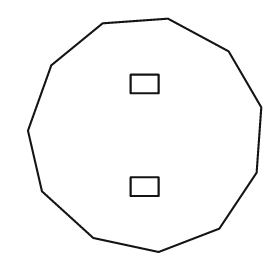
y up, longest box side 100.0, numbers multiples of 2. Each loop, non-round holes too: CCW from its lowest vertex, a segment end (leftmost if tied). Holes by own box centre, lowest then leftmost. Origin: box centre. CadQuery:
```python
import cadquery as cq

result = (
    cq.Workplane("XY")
    .moveTo(6.0, -50.0)
    .lineTo(32.0, -40.0)
    .lineTo(48.0, -16.0)
    .lineTo(50.0, 12.0)
    .lineTo(36.0, 36.0)
    .lineTo(10.0, 50.0)
    .lineTo(-18.0, 48.0)
    .lineTo(-40.0, 30.0)
    .lineTo(-50.0, 2.0)
    .lineTo(-44.0, -24.0)
    .lineTo(-22.0, -44.0)
    .close()
    .moveTo(-6.0, -26.0)
    .lineTo(6.0, -26.0)
    .lineTo(6.0, -18.0)
    .lineTo(-6.0, -18.0)
    .close()
    .moveTo(-6.0, 18.0)
    .lineTo(6.0, 18.0)
    .lineTo(6.0, 26.0)
    .lineTo(-6.0, 26.0)
    .close()
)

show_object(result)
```